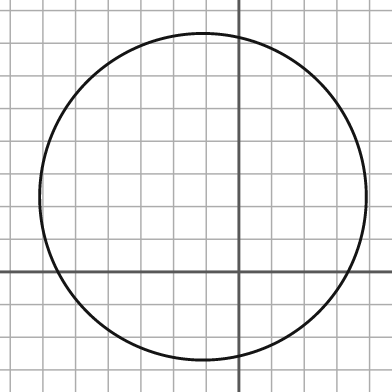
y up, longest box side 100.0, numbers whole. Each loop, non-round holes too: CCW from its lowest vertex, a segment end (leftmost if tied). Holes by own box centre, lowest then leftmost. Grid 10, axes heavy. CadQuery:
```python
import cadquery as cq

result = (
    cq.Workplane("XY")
    .moveTo(-11.0, 23.0)
    .circle(50.0)
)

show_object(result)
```